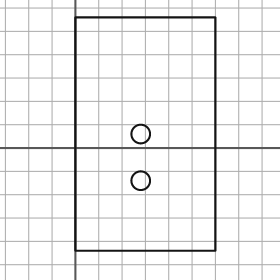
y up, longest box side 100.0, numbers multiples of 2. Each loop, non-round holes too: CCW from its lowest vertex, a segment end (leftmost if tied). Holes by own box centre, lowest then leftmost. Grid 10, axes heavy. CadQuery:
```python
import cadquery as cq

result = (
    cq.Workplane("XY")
    .moveTo(0.0, -44.0)
    .lineTo(60.0, -44.0)
    .lineTo(60.0, 56.0)
    .lineTo(0.0, 56.0)
    .close()
    .moveTo(28.0, -14.0)
    .circle(4.0)
    .moveTo(28.0, 6.0)
    .circle(4.0)
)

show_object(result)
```